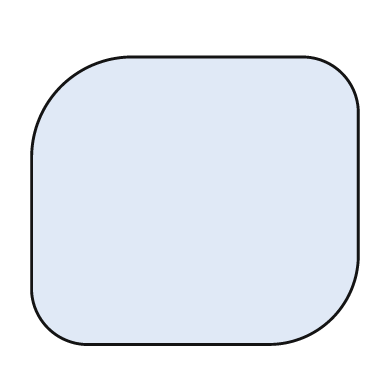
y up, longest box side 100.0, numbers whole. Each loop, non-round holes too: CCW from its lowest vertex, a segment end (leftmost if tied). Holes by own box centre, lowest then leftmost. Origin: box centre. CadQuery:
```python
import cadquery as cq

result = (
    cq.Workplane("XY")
    .moveTo(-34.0, -44.0)
    .lineTo(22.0, -44.0)
    .threePointArc((42.0, -36.0), (50.0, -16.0))
    .lineTo(50.0, 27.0)
    .threePointArc((45.0, 39.0), (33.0, 44.0))
    .lineTo(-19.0, 44.0)
    .threePointArc((-41.0, 35.0), (-50.0, 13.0))
    .lineTo(-50.0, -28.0)
    .threePointArc((-45.0, -39.0), (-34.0, -44.0))
    .close()
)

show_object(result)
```